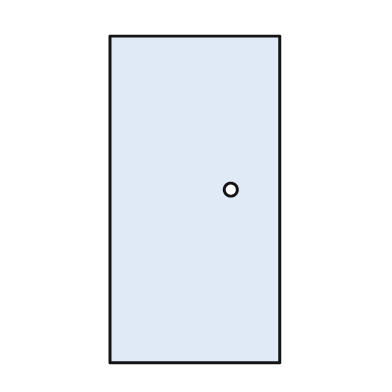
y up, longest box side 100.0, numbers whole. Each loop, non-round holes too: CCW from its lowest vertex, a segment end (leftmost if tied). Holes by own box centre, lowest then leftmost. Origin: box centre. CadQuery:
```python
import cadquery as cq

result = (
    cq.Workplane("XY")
    .moveTo(-26.0, -50.0)
    .lineTo(26.0, -50.0)
    .lineTo(26.0, 50.0)
    .lineTo(-26.0, 50.0)
    .close()
    .moveTo(11.0, 3.0)
    .circle(2.0)
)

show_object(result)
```